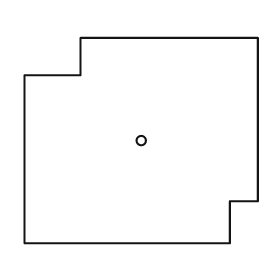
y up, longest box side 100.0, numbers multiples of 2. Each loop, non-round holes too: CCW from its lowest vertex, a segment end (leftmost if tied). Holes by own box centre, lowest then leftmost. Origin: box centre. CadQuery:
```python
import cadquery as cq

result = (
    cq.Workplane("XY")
    .moveTo(-50.0, -44.0)
    .lineTo(38.0, -44.0)
    .lineTo(38.0, -26.0)
    .lineTo(50.0, -26.0)
    .lineTo(50.0, 44.0)
    .lineTo(-26.0, 44.0)
    .lineTo(-26.0, 28.0)
    .lineTo(-50.0, 28.0)
    .close()
    .moveTo(0.0, 0.0)
    .circle(2.0)
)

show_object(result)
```